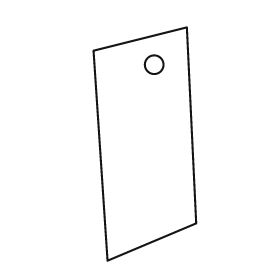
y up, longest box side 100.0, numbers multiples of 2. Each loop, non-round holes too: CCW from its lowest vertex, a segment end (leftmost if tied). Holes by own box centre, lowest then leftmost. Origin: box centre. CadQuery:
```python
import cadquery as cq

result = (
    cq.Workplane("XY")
    .moveTo(-16.0, -50.0)
    .lineTo(22.0, -34.0)
    .lineTo(18.0, 50.0)
    .lineTo(-22.0, 40.0)
    .close()
    .moveTo(4.0, 34.0)
    .circle(4.0)
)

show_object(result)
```